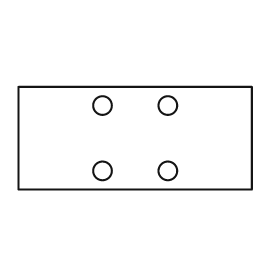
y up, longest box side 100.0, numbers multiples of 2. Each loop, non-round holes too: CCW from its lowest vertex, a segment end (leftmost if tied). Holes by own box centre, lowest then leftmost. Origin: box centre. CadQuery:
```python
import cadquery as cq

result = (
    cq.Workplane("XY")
    .moveTo(-50.0, -22.0)
    .lineTo(50.0, -22.0)
    .lineTo(50.0, 22.0)
    .lineTo(-50.0, 22.0)
    .close()
    .moveTo(-14.0, -14.0)
    .circle(4.0)
    .moveTo(14.0, -14.0)
    .circle(4.0)
    .moveTo(-14.0, 14.0)
    .circle(4.0)
    .moveTo(14.0, 14.0)
    .circle(4.0)
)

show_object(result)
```